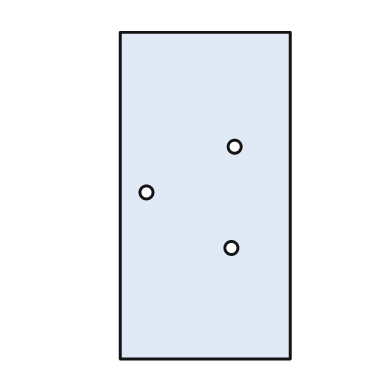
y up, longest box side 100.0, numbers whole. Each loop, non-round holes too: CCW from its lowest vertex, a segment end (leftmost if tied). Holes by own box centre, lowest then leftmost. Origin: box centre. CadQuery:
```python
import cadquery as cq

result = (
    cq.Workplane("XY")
    .moveTo(-26.0, -50.0)
    .lineTo(26.0, -50.0)
    .lineTo(26.0, 50.0)
    .lineTo(-26.0, 50.0)
    .close()
    .moveTo(8.0, -16.0)
    .circle(2.0)
    .moveTo(-18.0, 1.0)
    .circle(2.0)
    .moveTo(9.0, 15.0)
    .circle(2.0)
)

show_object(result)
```